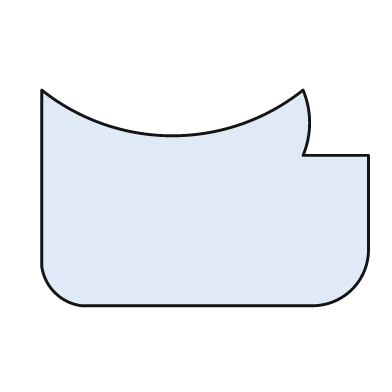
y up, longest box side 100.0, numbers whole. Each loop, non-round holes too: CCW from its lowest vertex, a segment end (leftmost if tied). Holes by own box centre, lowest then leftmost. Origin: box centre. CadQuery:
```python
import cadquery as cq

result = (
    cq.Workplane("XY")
    .moveTo(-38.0, -33.0)
    .lineTo(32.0, -33.0)
    .threePointArc((45.0, -28.0), (50.0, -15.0))
    .lineTo(50.0, 13.0)
    .lineTo(30.0, 13.0)
    .threePointArc((32.0, 23.0), (30.0, 33.0))
    .threePointArc((-10.0, 19.0), (-50.0, 33.0))
    .lineTo(-50.0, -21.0)
    .threePointArc((-46.0, -29.0), (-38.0, -33.0))
    .close()
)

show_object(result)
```